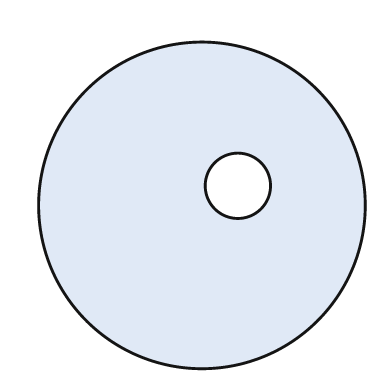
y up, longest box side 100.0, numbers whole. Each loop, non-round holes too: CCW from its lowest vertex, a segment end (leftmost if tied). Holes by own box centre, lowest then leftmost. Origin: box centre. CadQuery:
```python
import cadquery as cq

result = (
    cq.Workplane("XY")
    .moveTo(0.0, 0.0)
    .circle(50.0)
    .moveTo(11.0, 6.0)
    .circle(10.0)
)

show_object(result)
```